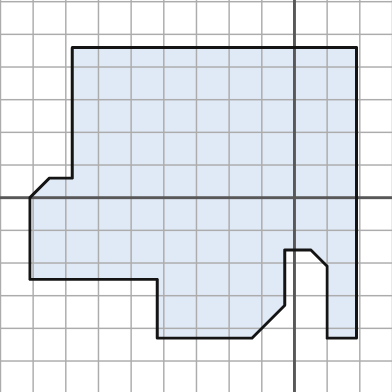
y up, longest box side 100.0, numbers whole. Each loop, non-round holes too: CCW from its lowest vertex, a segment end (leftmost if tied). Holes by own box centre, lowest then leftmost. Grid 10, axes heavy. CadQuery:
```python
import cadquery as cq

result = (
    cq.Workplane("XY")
    .moveTo(-42.0, -43.0)
    .lineTo(-13.0, -43.0)
    .lineTo(-3.0, -33.0)
    .lineTo(-3.0, -16.0)
    .lineTo(5.0, -16.0)
    .lineTo(10.0, -21.0)
    .lineTo(10.0, -43.0)
    .lineTo(19.0, -43.0)
    .lineTo(19.0, 46.0)
    .lineTo(-68.0, 46.0)
    .lineTo(-68.0, 6.0)
    .lineTo(-75.0, 6.0)
    .lineTo(-81.0, 0.0)
    .lineTo(-81.0, -25.0)
    .lineTo(-42.0, -25.0)
    .close()
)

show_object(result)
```